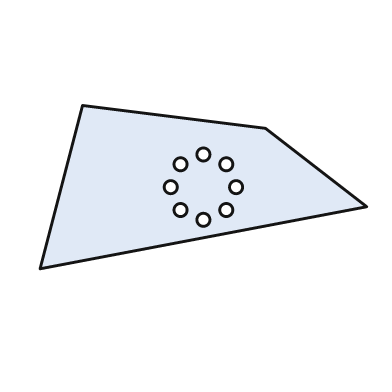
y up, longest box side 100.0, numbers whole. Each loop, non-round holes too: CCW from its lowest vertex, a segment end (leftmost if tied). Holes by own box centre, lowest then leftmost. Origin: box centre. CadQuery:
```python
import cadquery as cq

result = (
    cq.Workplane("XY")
    .moveTo(-50.0, -25.0)
    .lineTo(50.0, -6.0)
    .lineTo(19.0, 18.0)
    .lineTo(-37.0, 25.0)
    .close()
    .moveTo(0.0, -10.0)
    .circle(2.0)
    .moveTo(-7.0, -7.0)
    .circle(2.0)
    .moveTo(7.0, -7.0)
    .circle(2.0)
    .moveTo(-10.0, 0.0)
    .circle(2.0)
    .moveTo(10.0, 0.0)
    .circle(2.0)
    .moveTo(-7.0, 7.0)
    .circle(2.0)
    .moveTo(7.0, 7.0)
    .circle(2.0)
    .moveTo(0.0, 10.0)
    .circle(2.0)
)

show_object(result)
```